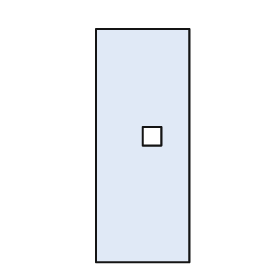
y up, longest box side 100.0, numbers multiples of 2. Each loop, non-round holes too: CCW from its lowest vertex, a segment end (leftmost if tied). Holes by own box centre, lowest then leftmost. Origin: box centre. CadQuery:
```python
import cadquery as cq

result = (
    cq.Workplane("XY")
    .moveTo(-20.0, -50.0)
    .lineTo(20.0, -50.0)
    .lineTo(20.0, 50.0)
    .lineTo(-20.0, 50.0)
    .close()
    .moveTo(0.0, 0.0)
    .lineTo(8.0, 0.0)
    .lineTo(8.0, 8.0)
    .lineTo(0.0, 8.0)
    .close()
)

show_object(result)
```